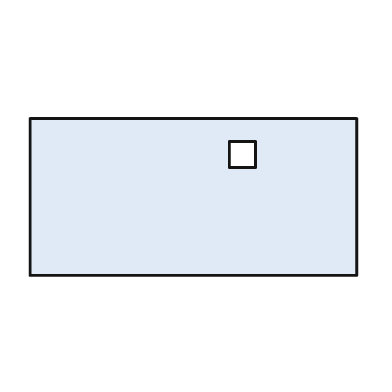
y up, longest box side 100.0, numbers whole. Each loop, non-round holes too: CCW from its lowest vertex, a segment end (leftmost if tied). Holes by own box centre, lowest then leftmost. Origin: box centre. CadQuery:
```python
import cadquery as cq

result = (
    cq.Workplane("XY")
    .moveTo(-50.0, -24.0)
    .lineTo(50.0, -24.0)
    .lineTo(50.0, 24.0)
    .lineTo(-50.0, 24.0)
    .close()
    .moveTo(11.0, 9.0)
    .lineTo(19.0, 9.0)
    .lineTo(19.0, 17.0)
    .lineTo(11.0, 17.0)
    .close()
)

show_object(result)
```